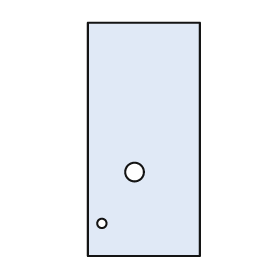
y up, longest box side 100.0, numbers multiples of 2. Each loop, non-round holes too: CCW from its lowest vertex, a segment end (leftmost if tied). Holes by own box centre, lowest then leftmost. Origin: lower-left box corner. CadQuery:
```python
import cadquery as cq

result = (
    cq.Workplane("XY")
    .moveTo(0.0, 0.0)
    .lineTo(48.0, 0.0)
    .lineTo(48.0, 100.0)
    .lineTo(0.0, 100.0)
    .close()
    .moveTo(6.0, 14.0)
    .circle(2.0)
    .moveTo(20.0, 36.0)
    .circle(4.0)
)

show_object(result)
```